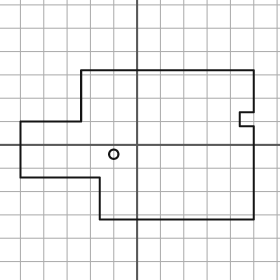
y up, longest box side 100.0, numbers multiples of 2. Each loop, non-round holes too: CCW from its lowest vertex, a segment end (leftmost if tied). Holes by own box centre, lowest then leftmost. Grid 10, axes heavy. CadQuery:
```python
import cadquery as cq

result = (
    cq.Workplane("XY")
    .moveTo(-16.0, -32.0)
    .lineTo(50.0, -32.0)
    .lineTo(50.0, 8.0)
    .lineTo(44.0, 8.0)
    .lineTo(44.0, 14.0)
    .lineTo(50.0, 14.0)
    .lineTo(50.0, 32.0)
    .lineTo(-24.0, 32.0)
    .lineTo(-24.0, 10.0)
    .lineTo(-50.0, 10.0)
    .lineTo(-50.0, -14.0)
    .lineTo(-16.0, -14.0)
    .close()
    .moveTo(-10.0, -4.0)
    .circle(2.0)
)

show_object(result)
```